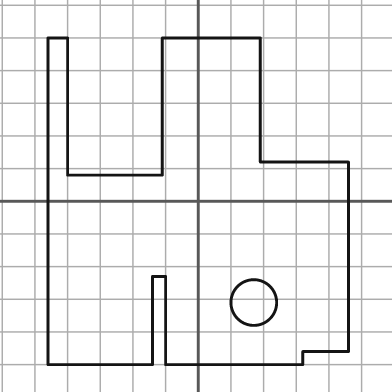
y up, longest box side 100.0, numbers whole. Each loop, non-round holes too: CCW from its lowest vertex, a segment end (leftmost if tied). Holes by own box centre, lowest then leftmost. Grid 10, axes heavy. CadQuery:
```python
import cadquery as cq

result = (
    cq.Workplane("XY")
    .moveTo(-46.0, -50.0)
    .lineTo(-14.0, -50.0)
    .lineTo(-14.0, -23.0)
    .lineTo(-10.0, -23.0)
    .lineTo(-10.0, -50.0)
    .lineTo(32.0, -50.0)
    .lineTo(32.0, -46.0)
    .lineTo(46.0, -46.0)
    .lineTo(46.0, 12.0)
    .lineTo(19.0, 12.0)
    .lineTo(19.0, 50.0)
    .lineTo(-11.0, 50.0)
    .lineTo(-11.0, 8.0)
    .lineTo(-40.0, 8.0)
    .lineTo(-40.0, 50.0)
    .lineTo(-46.0, 50.0)
    .close()
    .moveTo(17.0, -31.0)
    .circle(7.0)
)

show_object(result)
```